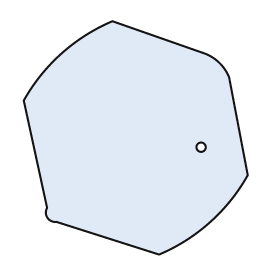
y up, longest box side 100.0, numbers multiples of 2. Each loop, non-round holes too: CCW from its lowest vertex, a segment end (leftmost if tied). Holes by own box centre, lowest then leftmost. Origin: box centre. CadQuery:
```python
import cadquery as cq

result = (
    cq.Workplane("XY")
    .moveTo(10.0, -50.0)
    .threePointArc((32.0, -36.0), (48.0, -16.0))
    .lineTo(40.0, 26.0)
    .threePointArc((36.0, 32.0), (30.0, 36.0))
    .lineTo(-10.0, 50.0)
    .threePointArc((-32.0, 36.0), (-48.0, 16.0))
    .lineTo(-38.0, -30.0)
    .threePointArc((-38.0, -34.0), (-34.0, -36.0))
    .close()
    .moveTo(28.0, -4.0)
    .circle(2.0)
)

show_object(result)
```